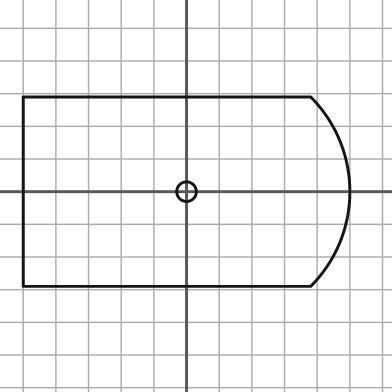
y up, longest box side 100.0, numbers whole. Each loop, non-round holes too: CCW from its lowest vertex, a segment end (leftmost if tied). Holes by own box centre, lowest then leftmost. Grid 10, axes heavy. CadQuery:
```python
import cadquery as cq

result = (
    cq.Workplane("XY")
    .moveTo(-50.0, -29.0)
    .lineTo(38.0, -29.0)
    .threePointArc((50.0, 0.0), (38.0, 29.0))
    .lineTo(-50.0, 29.0)
    .close()
    .moveTo(0.0, 0.0)
    .circle(3.0)
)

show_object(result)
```